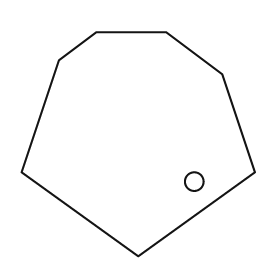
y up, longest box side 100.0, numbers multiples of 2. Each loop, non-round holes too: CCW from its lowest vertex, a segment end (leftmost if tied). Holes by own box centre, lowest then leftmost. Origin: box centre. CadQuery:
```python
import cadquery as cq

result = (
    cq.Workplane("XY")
    .moveTo(0.0, -48.0)
    .lineTo(50.0, -12.0)
    .lineTo(36.0, 30.0)
    .lineTo(12.0, 48.0)
    .lineTo(-18.0, 48.0)
    .lineTo(-34.0, 36.0)
    .lineTo(-50.0, -12.0)
    .close()
    .moveTo(24.0, -16.0)
    .circle(4.0)
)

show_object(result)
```